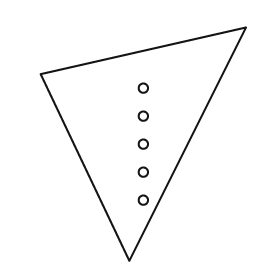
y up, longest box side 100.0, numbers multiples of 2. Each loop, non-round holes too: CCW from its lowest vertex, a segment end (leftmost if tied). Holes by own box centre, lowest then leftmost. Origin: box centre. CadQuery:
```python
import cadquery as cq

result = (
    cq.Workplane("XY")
    .moveTo(-6.0, -50.0)
    .lineTo(44.0, 50.0)
    .lineTo(-44.0, 30.0)
    .close()
    .moveTo(0.0, -24.0)
    .circle(2.0)
    .moveTo(0.0, -12.0)
    .circle(2.0)
    .moveTo(0.0, 0.0)
    .circle(2.0)
    .moveTo(0.0, 12.0)
    .circle(2.0)
    .moveTo(0.0, 24.0)
    .circle(2.0)
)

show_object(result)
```